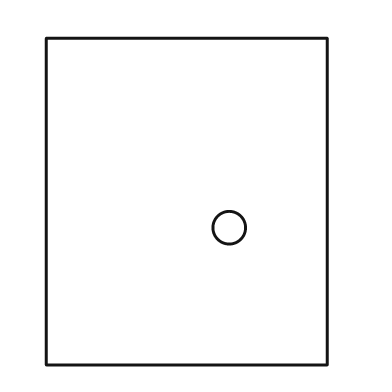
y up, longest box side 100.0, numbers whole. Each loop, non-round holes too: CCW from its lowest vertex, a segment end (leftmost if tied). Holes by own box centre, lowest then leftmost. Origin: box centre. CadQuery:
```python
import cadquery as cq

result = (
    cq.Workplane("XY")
    .moveTo(-43.0, -50.0)
    .lineTo(43.0, -50.0)
    .lineTo(43.0, 50.0)
    .lineTo(-43.0, 50.0)
    .close()
    .moveTo(13.0, -8.0)
    .circle(5.0)
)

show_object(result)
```